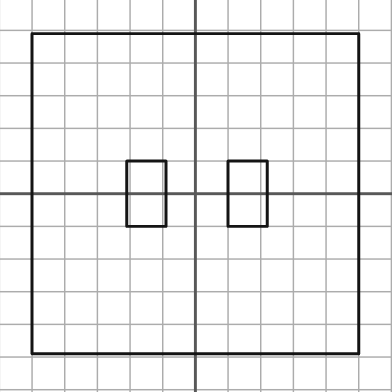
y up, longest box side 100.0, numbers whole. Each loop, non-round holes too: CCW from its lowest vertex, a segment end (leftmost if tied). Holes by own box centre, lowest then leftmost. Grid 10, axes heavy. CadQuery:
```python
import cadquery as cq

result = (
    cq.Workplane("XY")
    .moveTo(-50.0, -49.0)
    .lineTo(50.0, -49.0)
    .lineTo(50.0, 49.0)
    .lineTo(-50.0, 49.0)
    .close()
    .moveTo(-21.0, -10.0)
    .lineTo(-9.0, -10.0)
    .lineTo(-9.0, 10.0)
    .lineTo(-21.0, 10.0)
    .close()
    .moveTo(10.0, -10.0)
    .lineTo(22.0, -10.0)
    .lineTo(22.0, 10.0)
    .lineTo(10.0, 10.0)
    .close()
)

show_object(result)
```